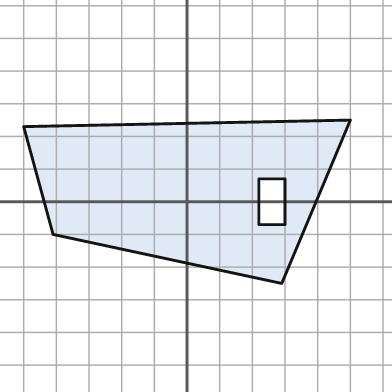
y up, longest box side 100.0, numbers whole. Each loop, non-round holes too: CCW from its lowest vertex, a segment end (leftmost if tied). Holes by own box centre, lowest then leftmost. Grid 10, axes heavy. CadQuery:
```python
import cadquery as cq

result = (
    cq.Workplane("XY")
    .moveTo(29.0, -25.0)
    .lineTo(50.0, 25.0)
    .lineTo(-50.0, 23.0)
    .lineTo(-41.0, -10.0)
    .close()
    .moveTo(22.0, -7.0)
    .lineTo(30.0, -7.0)
    .lineTo(30.0, 7.0)
    .lineTo(22.0, 7.0)
    .close()
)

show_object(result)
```